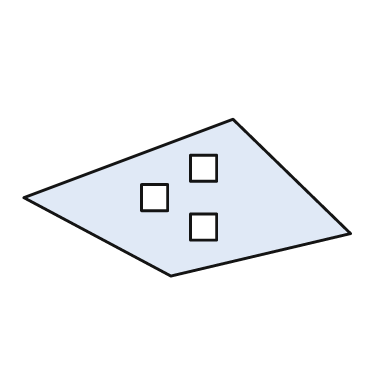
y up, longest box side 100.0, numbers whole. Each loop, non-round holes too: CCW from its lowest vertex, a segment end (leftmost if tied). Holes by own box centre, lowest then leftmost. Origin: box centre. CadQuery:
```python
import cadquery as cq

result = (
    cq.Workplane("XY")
    .moveTo(-5.0, -24.0)
    .lineTo(50.0, -11.0)
    .lineTo(14.0, 24.0)
    .lineTo(-50.0, 0.0)
    .close()
    .moveTo(1.0, -13.0)
    .lineTo(9.0, -13.0)
    .lineTo(9.0, -5.0)
    .lineTo(1.0, -5.0)
    .close()
    .moveTo(-14.0, -4.0)
    .lineTo(-6.0, -4.0)
    .lineTo(-6.0, 4.0)
    .lineTo(-14.0, 4.0)
    .close()
    .moveTo(1.0, 5.0)
    .lineTo(9.0, 5.0)
    .lineTo(9.0, 13.0)
    .lineTo(1.0, 13.0)
    .close()
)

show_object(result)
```